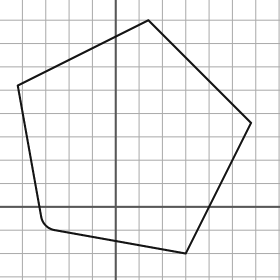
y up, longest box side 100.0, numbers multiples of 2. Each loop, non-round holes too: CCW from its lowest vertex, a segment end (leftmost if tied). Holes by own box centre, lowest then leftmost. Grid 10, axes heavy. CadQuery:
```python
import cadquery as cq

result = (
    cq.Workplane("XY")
    .moveTo(30.0, -20.0)
    .lineTo(58.0, 36.0)
    .lineTo(14.0, 80.0)
    .lineTo(-42.0, 52.0)
    .lineTo(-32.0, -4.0)
    .threePointArc((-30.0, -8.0), (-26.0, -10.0))
    .close()
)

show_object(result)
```